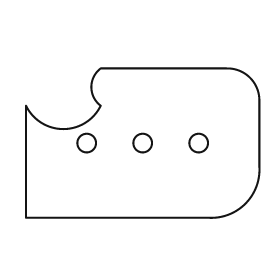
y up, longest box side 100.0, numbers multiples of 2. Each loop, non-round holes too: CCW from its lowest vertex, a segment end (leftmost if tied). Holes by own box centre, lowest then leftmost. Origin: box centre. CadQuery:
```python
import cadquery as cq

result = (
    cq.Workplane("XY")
    .moveTo(-50.0, -32.0)
    .lineTo(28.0, -32.0)
    .threePointArc((44.0, -26.0), (50.0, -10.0))
    .lineTo(50.0, 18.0)
    .threePointArc((46.0, 28.0), (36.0, 32.0))
    .lineTo(-18.0, 32.0)
    .threePointArc((-22.0, 24.0), (-18.0, 16.0))
    .threePointArc((-34.0, 6.0), (-50.0, 16.0))
    .close()
    .moveTo(-24.0, 0.0)
    .circle(4.0)
    .moveTo(0.0, 0.0)
    .circle(4.0)
    .moveTo(24.0, 0.0)
    .circle(4.0)
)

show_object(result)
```